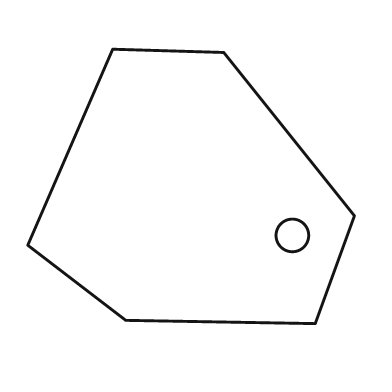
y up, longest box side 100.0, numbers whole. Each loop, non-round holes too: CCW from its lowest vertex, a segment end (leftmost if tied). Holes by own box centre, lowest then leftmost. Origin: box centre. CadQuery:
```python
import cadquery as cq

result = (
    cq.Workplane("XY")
    .moveTo(38.0, -42.0)
    .lineTo(50.0, -9.0)
    .lineTo(10.0, 41.0)
    .lineTo(-24.0, 42.0)
    .lineTo(-50.0, -18.0)
    .lineTo(-20.0, -41.0)
    .close()
    .moveTo(31.0, -15.0)
    .circle(5.0)
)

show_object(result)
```